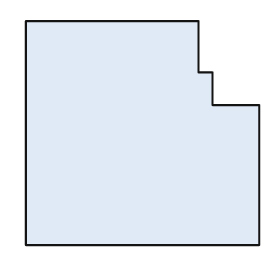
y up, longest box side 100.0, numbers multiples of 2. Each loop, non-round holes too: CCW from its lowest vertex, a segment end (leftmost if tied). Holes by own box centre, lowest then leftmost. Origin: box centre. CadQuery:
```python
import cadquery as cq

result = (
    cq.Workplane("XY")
    .moveTo(-50.0, -48.0)
    .lineTo(50.0, -48.0)
    .lineTo(50.0, 12.0)
    .lineTo(30.0, 12.0)
    .lineTo(30.0, 26.0)
    .lineTo(24.0, 26.0)
    .lineTo(24.0, 48.0)
    .lineTo(-50.0, 48.0)
    .close()
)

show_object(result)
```